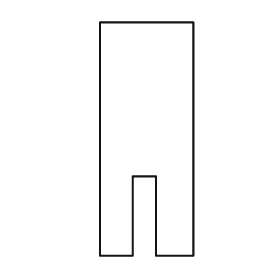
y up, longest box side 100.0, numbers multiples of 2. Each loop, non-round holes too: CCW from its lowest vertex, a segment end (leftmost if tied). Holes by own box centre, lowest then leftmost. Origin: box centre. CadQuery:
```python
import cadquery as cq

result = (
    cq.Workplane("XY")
    .moveTo(-20.0, -50.0)
    .lineTo(-6.0, -50.0)
    .lineTo(-6.0, -16.0)
    .lineTo(4.0, -16.0)
    .lineTo(4.0, -50.0)
    .lineTo(20.0, -50.0)
    .lineTo(20.0, 50.0)
    .lineTo(-20.0, 50.0)
    .close()
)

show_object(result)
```